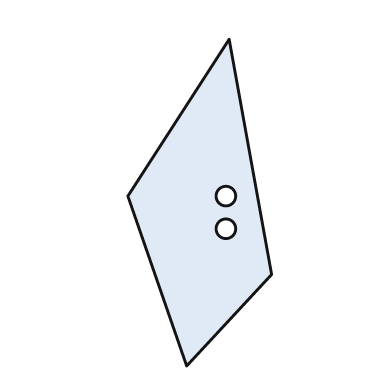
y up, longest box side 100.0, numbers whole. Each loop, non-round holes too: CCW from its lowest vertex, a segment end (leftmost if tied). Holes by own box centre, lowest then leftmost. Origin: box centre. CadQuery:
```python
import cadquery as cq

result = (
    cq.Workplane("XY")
    .moveTo(-4.0, -50.0)
    .lineTo(22.0, -22.0)
    .lineTo(9.0, 50.0)
    .lineTo(-22.0, 2.0)
    .close()
    .moveTo(8.0, -8.0)
    .circle(3.0)
    .moveTo(8.0, 2.0)
    .circle(3.0)
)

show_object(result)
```